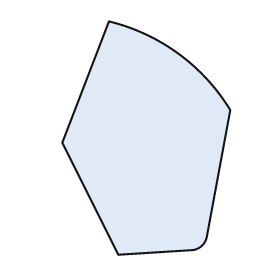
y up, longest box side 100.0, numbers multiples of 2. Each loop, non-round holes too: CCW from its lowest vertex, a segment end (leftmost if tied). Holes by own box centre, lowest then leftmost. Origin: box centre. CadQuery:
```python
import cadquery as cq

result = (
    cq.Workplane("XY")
    .moveTo(-12.0, -50.0)
    .lineTo(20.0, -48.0)
    .threePointArc((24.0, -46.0), (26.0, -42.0))
    .lineTo(36.0, 12.0)
    .threePointArc((14.0, 36.0), (-16.0, 50.0))
    .lineTo(-36.0, -2.0)
    .close()
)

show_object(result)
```